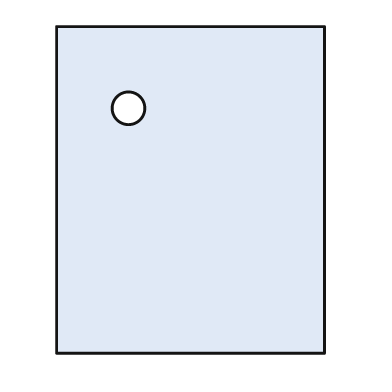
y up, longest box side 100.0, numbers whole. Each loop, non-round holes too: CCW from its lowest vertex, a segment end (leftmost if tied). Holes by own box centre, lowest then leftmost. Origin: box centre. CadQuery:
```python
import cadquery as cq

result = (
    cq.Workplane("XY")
    .moveTo(-41.0, -50.0)
    .lineTo(41.0, -50.0)
    .lineTo(41.0, 50.0)
    .lineTo(-41.0, 50.0)
    .close()
    .moveTo(-19.0, 25.0)
    .circle(5.0)
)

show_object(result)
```